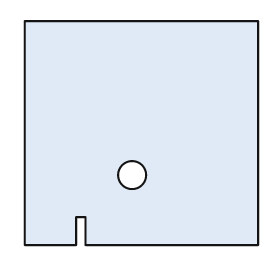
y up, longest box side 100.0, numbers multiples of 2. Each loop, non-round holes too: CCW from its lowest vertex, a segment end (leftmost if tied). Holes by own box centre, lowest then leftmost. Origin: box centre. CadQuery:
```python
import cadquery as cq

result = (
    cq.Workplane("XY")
    .moveTo(-50.0, -48.0)
    .lineTo(-28.0, -48.0)
    .lineTo(-28.0, -36.0)
    .lineTo(-24.0, -36.0)
    .lineTo(-24.0, -48.0)
    .lineTo(50.0, -48.0)
    .lineTo(50.0, 48.0)
    .lineTo(-50.0, 48.0)
    .close()
    .moveTo(-4.0, -18.0)
    .circle(6.0)
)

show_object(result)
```